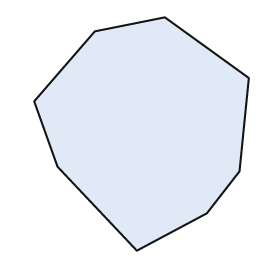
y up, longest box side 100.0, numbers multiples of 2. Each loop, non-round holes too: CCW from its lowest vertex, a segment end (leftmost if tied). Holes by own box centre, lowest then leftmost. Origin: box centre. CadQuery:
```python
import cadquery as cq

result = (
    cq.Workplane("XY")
    .moveTo(-2.0, -50.0)
    .lineTo(28.0, -34.0)
    .lineTo(42.0, -16.0)
    .lineTo(46.0, 24.0)
    .lineTo(10.0, 50.0)
    .lineTo(-20.0, 44.0)
    .lineTo(-46.0, 14.0)
    .lineTo(-36.0, -14.0)
    .close()
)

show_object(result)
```